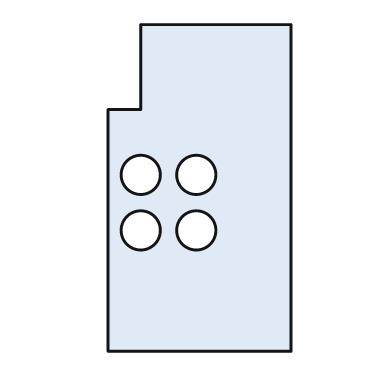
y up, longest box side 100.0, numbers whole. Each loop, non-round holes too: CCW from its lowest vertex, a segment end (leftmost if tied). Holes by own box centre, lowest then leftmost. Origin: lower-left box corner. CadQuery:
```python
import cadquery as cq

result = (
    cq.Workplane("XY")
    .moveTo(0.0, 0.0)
    .lineTo(56.0, 0.0)
    .lineTo(56.0, 100.0)
    .lineTo(10.0, 100.0)
    .lineTo(10.0, 74.0)
    .lineTo(0.0, 74.0)
    .close()
    .moveTo(10.0, 37.0)
    .circle(6.0)
    .moveTo(27.0, 37.0)
    .circle(6.0)
    .moveTo(10.0, 54.0)
    .circle(6.0)
    .moveTo(27.0, 54.0)
    .circle(6.0)
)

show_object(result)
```